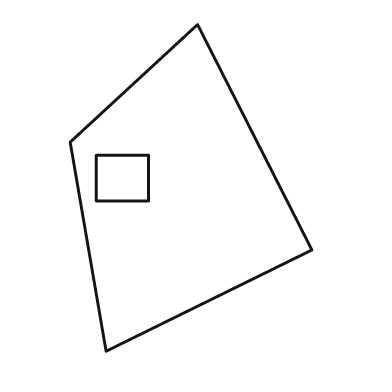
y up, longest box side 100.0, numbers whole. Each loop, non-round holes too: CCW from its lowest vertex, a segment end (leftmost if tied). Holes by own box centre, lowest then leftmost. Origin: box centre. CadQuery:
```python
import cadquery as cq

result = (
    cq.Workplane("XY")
    .moveTo(-26.0, -50.0)
    .lineTo(37.0, -19.0)
    .lineTo(2.0, 50.0)
    .lineTo(-37.0, 14.0)
    .close()
    .moveTo(-29.0, -4.0)
    .lineTo(-13.0, -4.0)
    .lineTo(-13.0, 10.0)
    .lineTo(-29.0, 10.0)
    .close()
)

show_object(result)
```